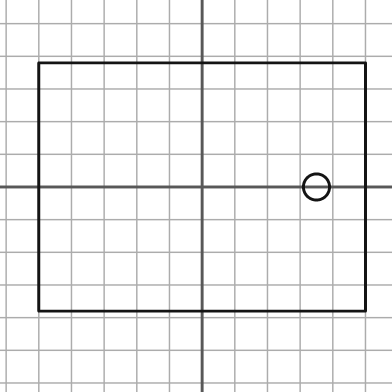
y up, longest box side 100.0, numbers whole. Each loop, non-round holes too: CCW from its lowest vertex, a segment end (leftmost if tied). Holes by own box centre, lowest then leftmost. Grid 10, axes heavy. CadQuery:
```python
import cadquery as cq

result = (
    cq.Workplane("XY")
    .moveTo(-50.0, -38.0)
    .lineTo(50.0, -38.0)
    .lineTo(50.0, 38.0)
    .lineTo(-50.0, 38.0)
    .close()
    .moveTo(35.0, 0.0)
    .circle(4.0)
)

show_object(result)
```